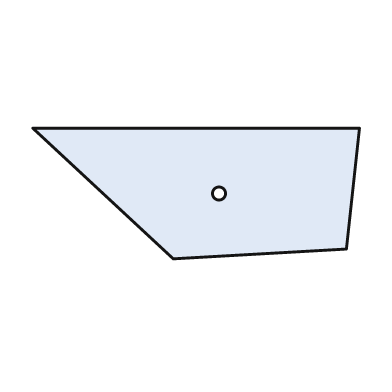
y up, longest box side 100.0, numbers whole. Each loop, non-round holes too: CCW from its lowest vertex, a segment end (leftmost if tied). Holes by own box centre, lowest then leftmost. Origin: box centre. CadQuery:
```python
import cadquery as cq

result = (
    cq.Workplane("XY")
    .moveTo(-7.0, -20.0)
    .lineTo(46.0, -17.0)
    .lineTo(50.0, 20.0)
    .lineTo(-50.0, 20.0)
    .close()
    .moveTo(7.0, 0.0)
    .circle(2.0)
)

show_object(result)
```